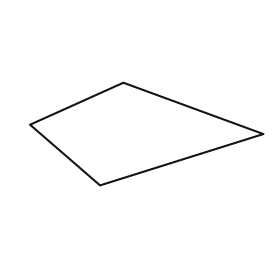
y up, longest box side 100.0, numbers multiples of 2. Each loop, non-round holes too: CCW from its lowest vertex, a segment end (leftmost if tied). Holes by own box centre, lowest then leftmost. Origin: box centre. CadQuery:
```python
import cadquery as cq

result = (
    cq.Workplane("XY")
    .moveTo(-20.0, -22.0)
    .lineTo(50.0, 0.0)
    .lineTo(-10.0, 22.0)
    .lineTo(-50.0, 4.0)
    .close()
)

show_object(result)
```